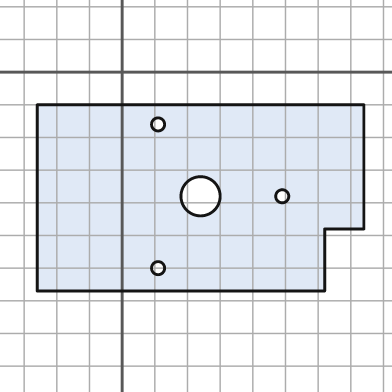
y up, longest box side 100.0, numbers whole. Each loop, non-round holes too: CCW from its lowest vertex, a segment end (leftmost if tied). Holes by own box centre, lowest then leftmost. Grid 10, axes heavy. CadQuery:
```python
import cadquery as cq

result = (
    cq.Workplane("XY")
    .moveTo(-26.0, -67.0)
    .lineTo(62.0, -67.0)
    .lineTo(62.0, -48.0)
    .lineTo(74.0, -48.0)
    .lineTo(74.0, -10.0)
    .lineTo(-26.0, -10.0)
    .close()
    .moveTo(11.0, -60.0)
    .circle(2.0)
    .moveTo(24.0, -38.0)
    .circle(6.0)
    .moveTo(49.0, -38.0)
    .circle(2.0)
    .moveTo(11.0, -16.0)
    .circle(2.0)
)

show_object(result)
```